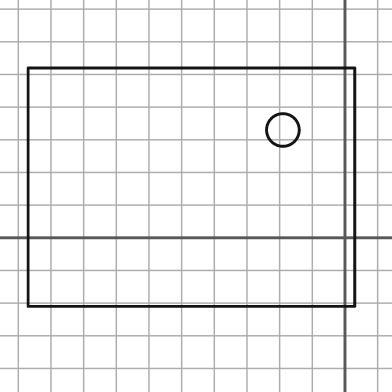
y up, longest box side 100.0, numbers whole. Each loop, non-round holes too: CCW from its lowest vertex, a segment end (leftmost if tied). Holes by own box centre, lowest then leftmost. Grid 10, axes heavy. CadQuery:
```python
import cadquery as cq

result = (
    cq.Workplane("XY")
    .moveTo(-97.0, -21.0)
    .lineTo(3.0, -21.0)
    .lineTo(3.0, 52.0)
    .lineTo(-97.0, 52.0)
    .close()
    .moveTo(-19.0, 33.0)
    .circle(5.0)
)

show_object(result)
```